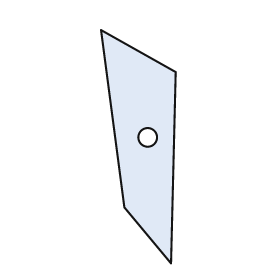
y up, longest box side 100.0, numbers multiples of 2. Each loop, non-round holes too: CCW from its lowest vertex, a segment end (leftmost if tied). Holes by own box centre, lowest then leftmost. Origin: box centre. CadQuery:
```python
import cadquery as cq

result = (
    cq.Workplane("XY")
    .moveTo(14.0, -50.0)
    .lineTo(16.0, 32.0)
    .lineTo(-16.0, 50.0)
    .lineTo(-6.0, -26.0)
    .close()
    .moveTo(4.0, 4.0)
    .circle(4.0)
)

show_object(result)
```